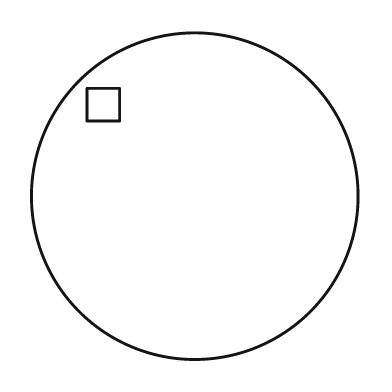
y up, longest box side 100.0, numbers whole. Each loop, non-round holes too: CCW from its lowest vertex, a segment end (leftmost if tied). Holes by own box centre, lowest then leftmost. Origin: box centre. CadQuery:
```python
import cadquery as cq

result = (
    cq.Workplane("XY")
    .moveTo(0.0, 0.0)
    .circle(50.0)
    .moveTo(-33.0, 23.0)
    .lineTo(-23.0, 23.0)
    .lineTo(-23.0, 33.0)
    .lineTo(-33.0, 33.0)
    .close()
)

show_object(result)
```